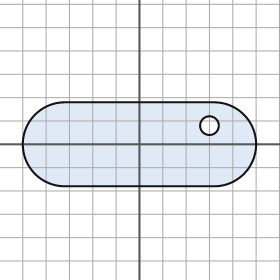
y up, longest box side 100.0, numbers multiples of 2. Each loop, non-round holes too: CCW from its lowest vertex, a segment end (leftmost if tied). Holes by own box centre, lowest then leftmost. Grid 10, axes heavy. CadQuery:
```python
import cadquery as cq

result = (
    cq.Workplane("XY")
    .moveTo(-32.0, -18.0)
    .lineTo(32.0, -18.0)
    .threePointArc((50.0, 0.0), (32.0, 18.0))
    .lineTo(-32.0, 18.0)
    .threePointArc((-50.0, 0.0), (-32.0, -18.0))
    .close()
    .moveTo(30.0, 8.0)
    .circle(4.0)
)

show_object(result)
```